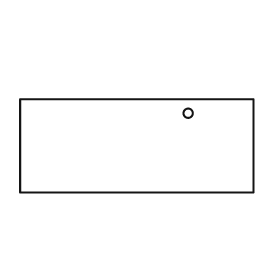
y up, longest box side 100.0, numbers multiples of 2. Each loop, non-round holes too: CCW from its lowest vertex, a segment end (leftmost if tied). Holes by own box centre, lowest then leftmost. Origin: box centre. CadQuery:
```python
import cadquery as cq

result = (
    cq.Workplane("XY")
    .moveTo(-50.0, -20.0)
    .lineTo(50.0, -20.0)
    .lineTo(50.0, 20.0)
    .lineTo(-50.0, 20.0)
    .close()
    .moveTo(22.0, 14.0)
    .circle(2.0)
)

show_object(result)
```